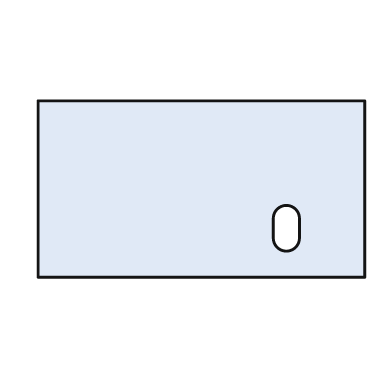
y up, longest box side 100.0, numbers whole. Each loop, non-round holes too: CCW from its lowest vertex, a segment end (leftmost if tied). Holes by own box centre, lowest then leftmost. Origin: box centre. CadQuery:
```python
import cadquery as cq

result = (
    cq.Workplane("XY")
    .moveTo(-50.0, -27.0)
    .lineTo(50.0, -27.0)
    .lineTo(50.0, 27.0)
    .lineTo(-50.0, 27.0)
    .close()
    .moveTo(22.0, -15.0)
    .threePointArc((26.0, -19.0), (30.0, -15.0))
    .lineTo(30.0, -9.0)
    .threePointArc((26.0, -5.0), (22.0, -9.0))
    .close()
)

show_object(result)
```